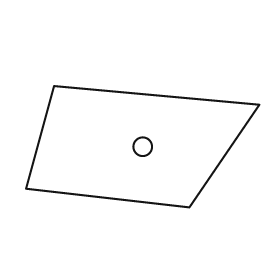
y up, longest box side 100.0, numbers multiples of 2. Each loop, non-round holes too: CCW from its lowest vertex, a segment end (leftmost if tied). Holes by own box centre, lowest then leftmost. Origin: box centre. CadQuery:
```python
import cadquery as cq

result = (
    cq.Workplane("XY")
    .moveTo(20.0, -26.0)
    .lineTo(50.0, 18.0)
    .lineTo(-38.0, 26.0)
    .lineTo(-50.0, -18.0)
    .close()
    .moveTo(0.0, 0.0)
    .circle(4.0)
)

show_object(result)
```